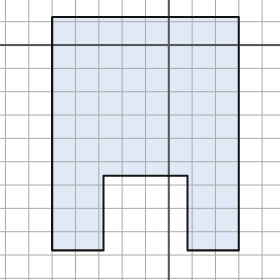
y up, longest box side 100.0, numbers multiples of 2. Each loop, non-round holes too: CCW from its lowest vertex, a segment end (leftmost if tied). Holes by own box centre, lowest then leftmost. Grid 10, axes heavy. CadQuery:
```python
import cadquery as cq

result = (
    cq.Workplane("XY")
    .moveTo(-50.0, -88.0)
    .lineTo(-28.0, -88.0)
    .lineTo(-28.0, -56.0)
    .lineTo(8.0, -56.0)
    .lineTo(8.0, -88.0)
    .lineTo(30.0, -88.0)
    .lineTo(30.0, 12.0)
    .lineTo(-50.0, 12.0)
    .close()
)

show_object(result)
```